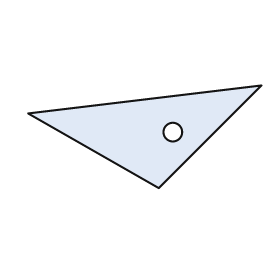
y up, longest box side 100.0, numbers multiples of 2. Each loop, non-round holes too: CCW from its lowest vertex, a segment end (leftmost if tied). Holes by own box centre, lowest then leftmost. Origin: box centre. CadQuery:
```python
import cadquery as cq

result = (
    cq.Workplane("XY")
    .moveTo(6.0, -22.0)
    .lineTo(50.0, 22.0)
    .lineTo(-50.0, 10.0)
    .close()
    .moveTo(12.0, 2.0)
    .circle(4.0)
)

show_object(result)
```